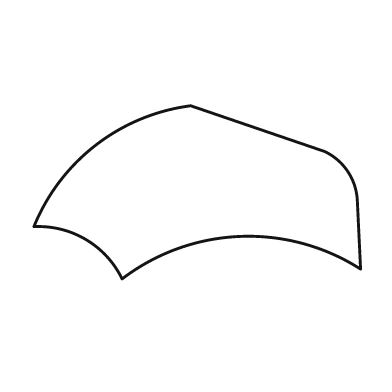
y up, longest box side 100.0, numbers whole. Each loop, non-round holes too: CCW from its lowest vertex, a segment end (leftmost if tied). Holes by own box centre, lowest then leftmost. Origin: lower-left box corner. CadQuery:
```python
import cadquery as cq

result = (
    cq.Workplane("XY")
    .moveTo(27.0, 0.0)
    .threePointArc((63.0, 13.0), (100.0, 3.0))
    .lineTo(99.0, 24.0)
    .threePointArc((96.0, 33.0), (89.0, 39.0))
    .lineTo(48.0, 53.0)
    .threePointArc((19.0, 41.0), (0.0, 16.0))
    .threePointArc((16.0, 12.0), (27.0, 0.0))
    .close()
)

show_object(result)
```